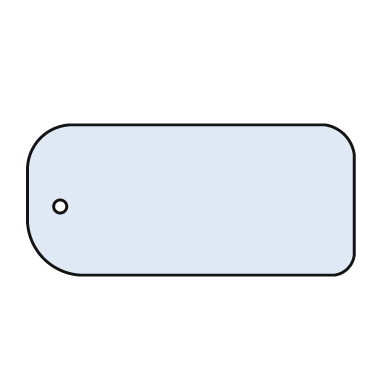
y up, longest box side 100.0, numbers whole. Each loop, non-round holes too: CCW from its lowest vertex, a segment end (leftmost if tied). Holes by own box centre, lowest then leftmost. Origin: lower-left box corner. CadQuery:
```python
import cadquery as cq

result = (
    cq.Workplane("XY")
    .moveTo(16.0, 0.0)
    .lineTo(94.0, 0.0)
    .threePointArc((98.0, 2.0), (100.0, 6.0))
    .lineTo(100.0, 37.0)
    .threePointArc((97.0, 43.0), (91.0, 46.0))
    .lineTo(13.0, 46.0)
    .threePointArc((4.0, 42.0), (0.0, 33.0))
    .lineTo(0.0, 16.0)
    .threePointArc((5.0, 5.0), (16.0, 0.0))
    .close()
    .moveTo(10.0, 21.0)
    .circle(2.0)
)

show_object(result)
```